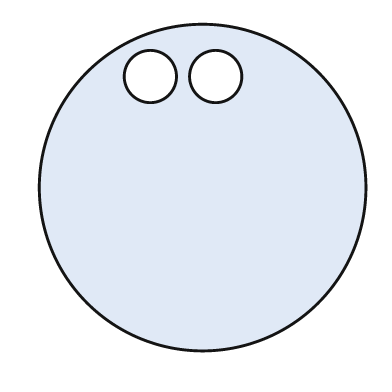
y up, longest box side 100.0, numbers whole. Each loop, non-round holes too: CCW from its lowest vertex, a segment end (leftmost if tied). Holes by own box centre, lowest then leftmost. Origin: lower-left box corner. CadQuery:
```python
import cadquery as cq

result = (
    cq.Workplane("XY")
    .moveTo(50.0, 50.0)
    .circle(50.0)
    .moveTo(34.0, 84.0)
    .circle(8.0)
    .moveTo(54.0, 84.0)
    .circle(8.0)
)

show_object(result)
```